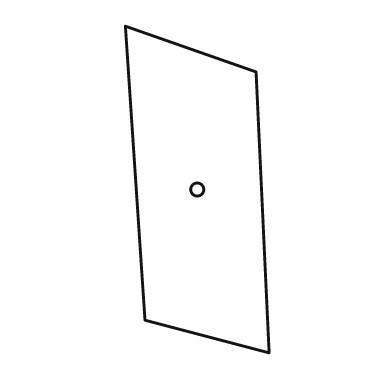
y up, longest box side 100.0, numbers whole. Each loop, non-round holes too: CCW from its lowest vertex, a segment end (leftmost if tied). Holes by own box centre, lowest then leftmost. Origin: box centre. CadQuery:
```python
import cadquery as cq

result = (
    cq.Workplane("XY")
    .moveTo(22.0, -50.0)
    .lineTo(18.0, 36.0)
    .lineTo(-22.0, 50.0)
    .lineTo(-16.0, -40.0)
    .close()
    .moveTo(0.0, 0.0)
    .circle(2.0)
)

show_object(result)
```